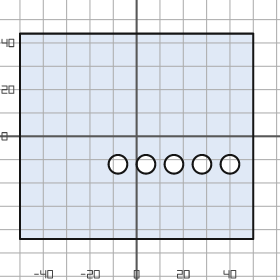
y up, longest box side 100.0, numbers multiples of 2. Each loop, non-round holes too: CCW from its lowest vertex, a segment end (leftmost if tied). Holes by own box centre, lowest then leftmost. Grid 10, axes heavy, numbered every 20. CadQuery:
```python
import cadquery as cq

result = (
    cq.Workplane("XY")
    .moveTo(-50.0, -44.0)
    .lineTo(50.0, -44.0)
    .lineTo(50.0, 44.0)
    .lineTo(-50.0, 44.0)
    .close()
    .moveTo(-8.0, -12.0)
    .circle(4.0)
    .moveTo(4.0, -12.0)
    .circle(4.0)
    .moveTo(16.0, -12.0)
    .circle(4.0)
    .moveTo(28.0, -12.0)
    .circle(4.0)
    .moveTo(40.0, -12.0)
    .circle(4.0)
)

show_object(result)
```